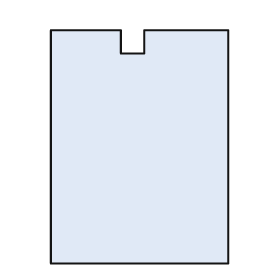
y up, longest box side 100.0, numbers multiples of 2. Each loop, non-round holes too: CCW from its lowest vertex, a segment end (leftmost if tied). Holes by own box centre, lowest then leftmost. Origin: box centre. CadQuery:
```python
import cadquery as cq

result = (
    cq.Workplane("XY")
    .moveTo(-38.0, -50.0)
    .lineTo(38.0, -50.0)
    .lineTo(38.0, 50.0)
    .lineTo(2.0, 50.0)
    .lineTo(2.0, 40.0)
    .lineTo(-8.0, 40.0)
    .lineTo(-8.0, 50.0)
    .lineTo(-38.0, 50.0)
    .close()
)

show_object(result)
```